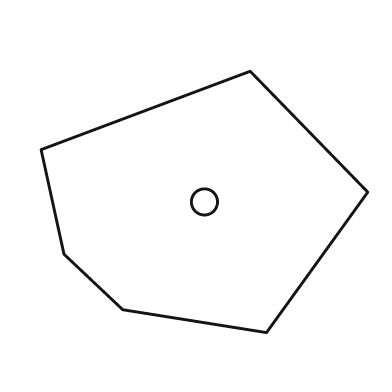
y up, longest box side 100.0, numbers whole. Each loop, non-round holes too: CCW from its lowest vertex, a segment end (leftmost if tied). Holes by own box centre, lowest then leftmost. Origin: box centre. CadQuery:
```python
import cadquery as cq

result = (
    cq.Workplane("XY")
    .moveTo(19.0, -40.0)
    .lineTo(50.0, 3.0)
    .lineTo(14.0, 40.0)
    .lineTo(-50.0, 16.0)
    .lineTo(-43.0, -16.0)
    .lineTo(-25.0, -33.0)
    .close()
    .moveTo(0.0, 0.0)
    .circle(4.0)
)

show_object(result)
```